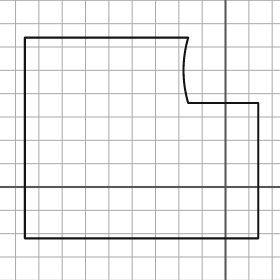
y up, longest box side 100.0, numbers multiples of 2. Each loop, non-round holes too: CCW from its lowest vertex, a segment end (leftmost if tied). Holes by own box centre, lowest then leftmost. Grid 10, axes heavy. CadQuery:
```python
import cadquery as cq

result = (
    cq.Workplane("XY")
    .moveTo(-86.0, -22.0)
    .lineTo(14.0, -22.0)
    .lineTo(14.0, 36.0)
    .lineTo(-16.0, 36.0)
    .threePointArc((-18.0, 50.0), (-16.0, 64.0))
    .lineTo(-86.0, 64.0)
    .close()
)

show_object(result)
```